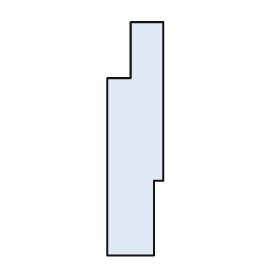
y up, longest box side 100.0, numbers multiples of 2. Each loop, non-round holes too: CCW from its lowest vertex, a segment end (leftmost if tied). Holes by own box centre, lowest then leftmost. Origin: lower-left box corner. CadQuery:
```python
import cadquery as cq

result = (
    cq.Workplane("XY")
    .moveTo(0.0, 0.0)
    .lineTo(20.0, 0.0)
    .lineTo(20.0, 32.0)
    .lineTo(24.0, 32.0)
    .lineTo(24.0, 100.0)
    .lineTo(10.0, 100.0)
    .lineTo(10.0, 76.0)
    .lineTo(0.0, 76.0)
    .close()
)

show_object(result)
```